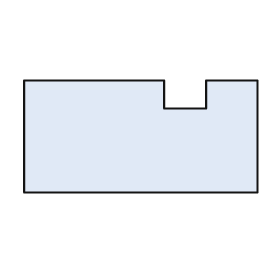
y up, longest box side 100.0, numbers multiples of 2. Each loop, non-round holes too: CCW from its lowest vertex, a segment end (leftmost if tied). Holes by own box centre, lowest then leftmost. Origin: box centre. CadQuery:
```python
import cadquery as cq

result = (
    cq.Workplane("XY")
    .moveTo(-50.0, -24.0)
    .lineTo(50.0, -24.0)
    .lineTo(50.0, 24.0)
    .lineTo(28.0, 24.0)
    .lineTo(28.0, 12.0)
    .lineTo(10.0, 12.0)
    .lineTo(10.0, 24.0)
    .lineTo(-50.0, 24.0)
    .close()
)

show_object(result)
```